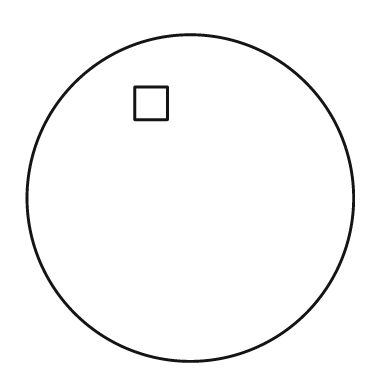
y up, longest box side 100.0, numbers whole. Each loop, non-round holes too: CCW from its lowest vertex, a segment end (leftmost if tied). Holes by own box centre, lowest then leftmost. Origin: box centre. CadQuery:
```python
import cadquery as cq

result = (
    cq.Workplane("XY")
    .moveTo(0.0, 0.0)
    .circle(50.0)
    .moveTo(-17.0, 24.0)
    .lineTo(-7.0, 24.0)
    .lineTo(-7.0, 34.0)
    .lineTo(-17.0, 34.0)
    .close()
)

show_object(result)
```